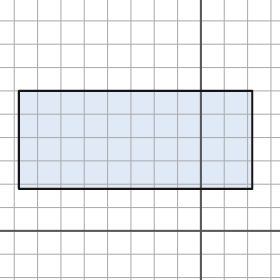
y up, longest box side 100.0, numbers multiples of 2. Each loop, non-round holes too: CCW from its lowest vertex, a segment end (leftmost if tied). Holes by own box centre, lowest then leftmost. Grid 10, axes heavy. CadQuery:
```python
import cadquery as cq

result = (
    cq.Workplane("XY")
    .moveTo(-78.0, 18.0)
    .lineTo(22.0, 18.0)
    .lineTo(22.0, 60.0)
    .lineTo(-78.0, 60.0)
    .close()
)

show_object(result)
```